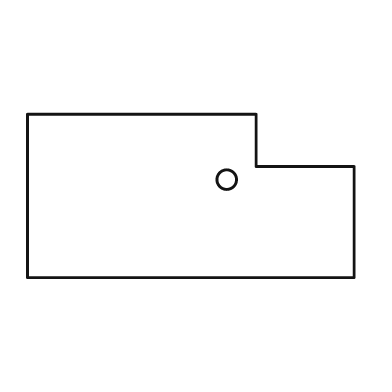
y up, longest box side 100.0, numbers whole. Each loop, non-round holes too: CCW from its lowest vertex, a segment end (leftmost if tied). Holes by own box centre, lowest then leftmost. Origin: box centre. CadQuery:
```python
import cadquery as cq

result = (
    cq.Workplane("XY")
    .moveTo(-50.0, -25.0)
    .lineTo(50.0, -25.0)
    .lineTo(50.0, 9.0)
    .lineTo(20.0, 9.0)
    .lineTo(20.0, 25.0)
    .lineTo(-50.0, 25.0)
    .close()
    .moveTo(11.0, 5.0)
    .circle(3.0)
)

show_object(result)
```